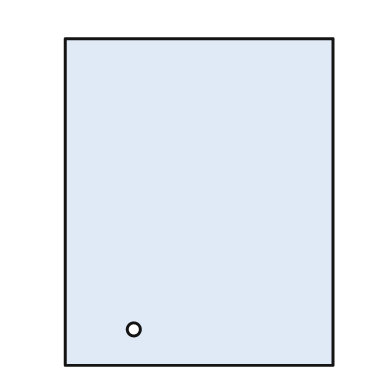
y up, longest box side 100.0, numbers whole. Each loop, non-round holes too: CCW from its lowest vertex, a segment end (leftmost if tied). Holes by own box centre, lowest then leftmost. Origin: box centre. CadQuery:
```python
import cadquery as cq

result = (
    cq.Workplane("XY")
    .moveTo(-41.0, -50.0)
    .lineTo(41.0, -50.0)
    .lineTo(41.0, 50.0)
    .lineTo(-41.0, 50.0)
    .close()
    .moveTo(-20.0, -39.0)
    .circle(2.0)
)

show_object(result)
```